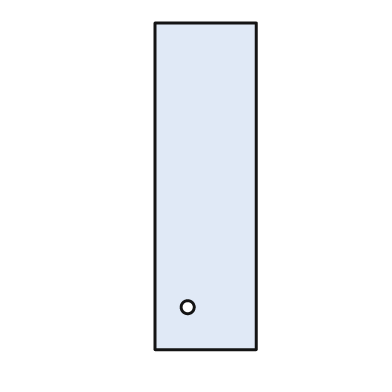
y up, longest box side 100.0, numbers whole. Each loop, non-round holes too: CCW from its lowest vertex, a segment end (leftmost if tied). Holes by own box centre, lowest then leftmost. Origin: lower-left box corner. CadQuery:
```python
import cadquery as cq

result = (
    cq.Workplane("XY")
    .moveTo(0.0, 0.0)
    .lineTo(31.0, 0.0)
    .lineTo(31.0, 100.0)
    .lineTo(0.0, 100.0)
    .close()
    .moveTo(10.0, 13.0)
    .circle(2.0)
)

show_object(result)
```